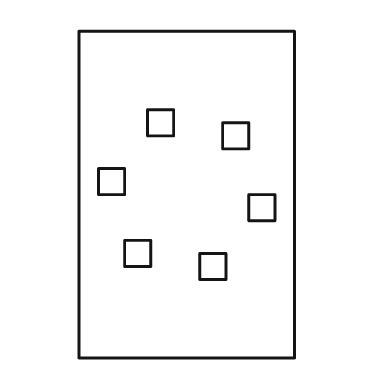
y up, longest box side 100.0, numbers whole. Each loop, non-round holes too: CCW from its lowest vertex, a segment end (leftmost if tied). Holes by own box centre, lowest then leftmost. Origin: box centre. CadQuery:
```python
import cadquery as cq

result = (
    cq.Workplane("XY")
    .moveTo(-33.0, -50.0)
    .lineTo(33.0, -50.0)
    .lineTo(33.0, 50.0)
    .lineTo(-33.0, 50.0)
    .close()
    .moveTo(4.0, -26.0)
    .lineTo(12.0, -26.0)
    .lineTo(12.0, -18.0)
    .lineTo(4.0, -18.0)
    .close()
    .moveTo(-19.0, -22.0)
    .lineTo(-11.0, -22.0)
    .lineTo(-11.0, -14.0)
    .lineTo(-19.0, -14.0)
    .close()
    .moveTo(19.0, -8.0)
    .lineTo(27.0, -8.0)
    .lineTo(27.0, 0.0)
    .lineTo(19.0, 0.0)
    .close()
    .moveTo(-27.0, 0.0)
    .lineTo(-19.0, 0.0)
    .lineTo(-19.0, 8.0)
    .lineTo(-27.0, 8.0)
    .close()
    .moveTo(11.0, 14.0)
    .lineTo(19.0, 14.0)
    .lineTo(19.0, 22.0)
    .lineTo(11.0, 22.0)
    .close()
    .moveTo(-12.0, 18.0)
    .lineTo(-4.0, 18.0)
    .lineTo(-4.0, 26.0)
    .lineTo(-12.0, 26.0)
    .close()
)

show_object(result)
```